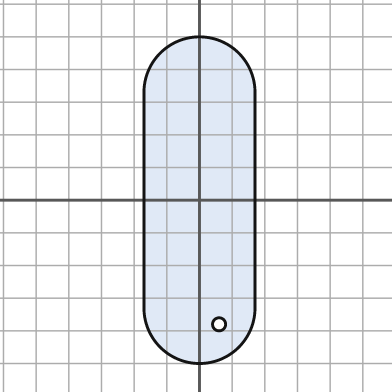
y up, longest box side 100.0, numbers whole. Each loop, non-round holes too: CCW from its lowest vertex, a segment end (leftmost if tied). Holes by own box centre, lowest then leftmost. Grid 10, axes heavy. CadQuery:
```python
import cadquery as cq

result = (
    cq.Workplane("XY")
    .moveTo(-17.0, -33.0)
    .threePointArc((0.0, -50.0), (17.0, -33.0))
    .lineTo(17.0, 33.0)
    .threePointArc((0.0, 50.0), (-17.0, 33.0))
    .close()
    .moveTo(6.0, -38.0)
    .circle(2.0)
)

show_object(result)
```